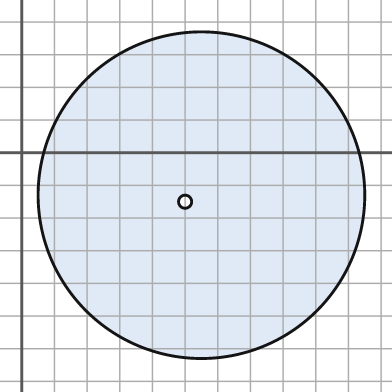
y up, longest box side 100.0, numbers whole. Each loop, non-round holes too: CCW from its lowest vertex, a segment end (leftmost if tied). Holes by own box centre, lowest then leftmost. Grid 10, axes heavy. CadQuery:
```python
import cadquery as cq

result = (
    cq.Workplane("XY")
    .moveTo(55.0, -13.0)
    .circle(50.0)
    .moveTo(50.0, -15.0)
    .circle(2.0)
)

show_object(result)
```